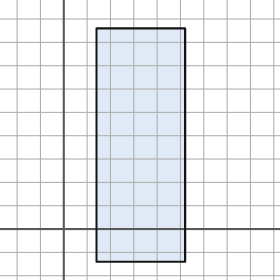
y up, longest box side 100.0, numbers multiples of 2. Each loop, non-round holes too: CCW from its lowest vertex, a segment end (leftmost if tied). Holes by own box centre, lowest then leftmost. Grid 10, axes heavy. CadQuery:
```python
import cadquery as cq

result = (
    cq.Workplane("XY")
    .moveTo(14.0, -14.0)
    .lineTo(52.0, -14.0)
    .lineTo(52.0, 86.0)
    .lineTo(14.0, 86.0)
    .close()
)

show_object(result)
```